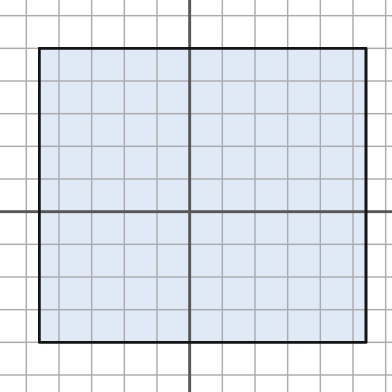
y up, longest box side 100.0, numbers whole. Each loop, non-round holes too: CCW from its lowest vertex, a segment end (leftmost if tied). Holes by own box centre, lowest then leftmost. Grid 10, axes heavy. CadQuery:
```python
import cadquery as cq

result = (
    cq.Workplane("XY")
    .moveTo(-46.0, -40.0)
    .lineTo(54.0, -40.0)
    .lineTo(54.0, 50.0)
    .lineTo(-46.0, 50.0)
    .close()
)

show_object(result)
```